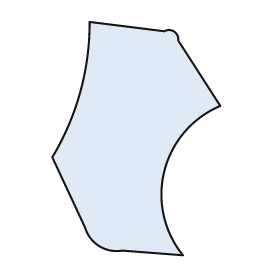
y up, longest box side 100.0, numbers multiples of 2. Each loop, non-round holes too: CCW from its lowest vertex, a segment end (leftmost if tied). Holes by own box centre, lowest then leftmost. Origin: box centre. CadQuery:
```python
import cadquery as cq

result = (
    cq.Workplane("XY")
    .moveTo(20.0, -50.0)
    .threePointArc((12.0, -14.0), (36.0, 14.0))
    .lineTo(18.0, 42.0)
    .threePointArc((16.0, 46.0), (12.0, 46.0))
    .lineTo(-20.0, 50.0)
    .threePointArc((-24.0, 20.0), (-36.0, -8.0))
    .lineTo(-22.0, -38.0)
    .threePointArc((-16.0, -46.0), (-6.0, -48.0))
    .close()
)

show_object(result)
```